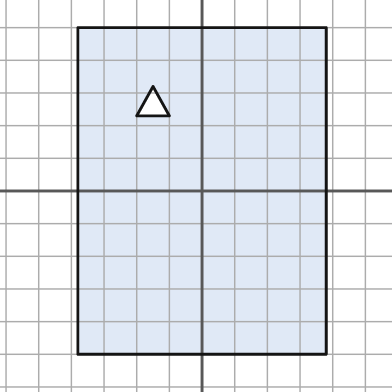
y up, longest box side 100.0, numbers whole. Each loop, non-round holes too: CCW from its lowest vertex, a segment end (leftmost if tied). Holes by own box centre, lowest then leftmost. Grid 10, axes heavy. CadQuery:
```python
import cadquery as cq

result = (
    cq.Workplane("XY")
    .moveTo(-38.0, -50.0)
    .lineTo(38.0, -50.0)
    .lineTo(38.0, 50.0)
    .lineTo(-38.0, 50.0)
    .close()
    .moveTo(-20.0, 23.0)
    .lineTo(-10.0, 23.0)
    .lineTo(-15.0, 32.0)
    .close()
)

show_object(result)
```